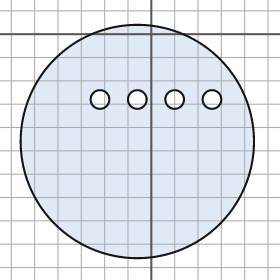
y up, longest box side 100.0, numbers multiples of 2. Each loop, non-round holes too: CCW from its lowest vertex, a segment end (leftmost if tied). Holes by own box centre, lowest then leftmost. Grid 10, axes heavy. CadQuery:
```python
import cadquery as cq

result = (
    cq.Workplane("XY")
    .moveTo(-6.0, -46.0)
    .circle(50.0)
    .moveTo(-22.0, -28.0)
    .circle(4.0)
    .moveTo(-6.0, -28.0)
    .circle(4.0)
    .moveTo(10.0, -28.0)
    .circle(4.0)
    .moveTo(26.0, -28.0)
    .circle(4.0)
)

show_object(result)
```